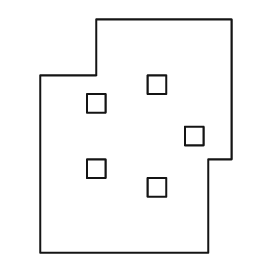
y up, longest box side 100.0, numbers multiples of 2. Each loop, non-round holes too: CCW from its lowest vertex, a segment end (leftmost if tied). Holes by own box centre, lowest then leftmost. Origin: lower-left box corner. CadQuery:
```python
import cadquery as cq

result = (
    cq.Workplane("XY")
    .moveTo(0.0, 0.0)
    .lineTo(72.0, 0.0)
    .lineTo(72.0, 40.0)
    .lineTo(82.0, 40.0)
    .lineTo(82.0, 100.0)
    .lineTo(24.0, 100.0)
    .lineTo(24.0, 76.0)
    .lineTo(0.0, 76.0)
    .close()
    .moveTo(46.0, 24.0)
    .lineTo(54.0, 24.0)
    .lineTo(54.0, 32.0)
    .lineTo(46.0, 32.0)
    .close()
    .moveTo(20.0, 32.0)
    .lineTo(28.0, 32.0)
    .lineTo(28.0, 40.0)
    .lineTo(20.0, 40.0)
    .close()
    .moveTo(62.0, 46.0)
    .lineTo(70.0, 46.0)
    .lineTo(70.0, 54.0)
    .lineTo(62.0, 54.0)
    .close()
    .moveTo(20.0, 60.0)
    .lineTo(28.0, 60.0)
    .lineTo(28.0, 68.0)
    .lineTo(20.0, 68.0)
    .close()
    .moveTo(46.0, 68.0)
    .lineTo(54.0, 68.0)
    .lineTo(54.0, 76.0)
    .lineTo(46.0, 76.0)
    .close()
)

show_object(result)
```